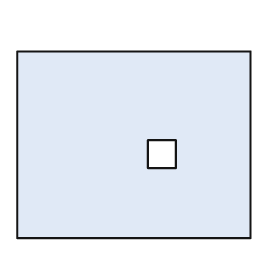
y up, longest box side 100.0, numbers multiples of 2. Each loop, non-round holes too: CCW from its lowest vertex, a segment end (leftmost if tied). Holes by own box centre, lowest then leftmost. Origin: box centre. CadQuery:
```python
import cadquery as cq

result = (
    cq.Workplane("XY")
    .moveTo(-50.0, -40.0)
    .lineTo(50.0, -40.0)
    .lineTo(50.0, 40.0)
    .lineTo(-50.0, 40.0)
    .close()
    .moveTo(6.0, -10.0)
    .lineTo(18.0, -10.0)
    .lineTo(18.0, 2.0)
    .lineTo(6.0, 2.0)
    .close()
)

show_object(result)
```